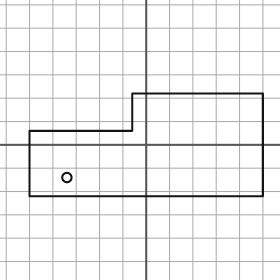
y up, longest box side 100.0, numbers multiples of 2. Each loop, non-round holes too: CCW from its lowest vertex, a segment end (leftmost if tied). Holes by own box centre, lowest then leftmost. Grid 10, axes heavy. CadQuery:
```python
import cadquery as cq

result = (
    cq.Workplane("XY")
    .moveTo(-50.0, -22.0)
    .lineTo(50.0, -22.0)
    .lineTo(50.0, 22.0)
    .lineTo(-6.0, 22.0)
    .lineTo(-6.0, 6.0)
    .lineTo(-50.0, 6.0)
    .close()
    .moveTo(-34.0, -14.0)
    .circle(2.0)
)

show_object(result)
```